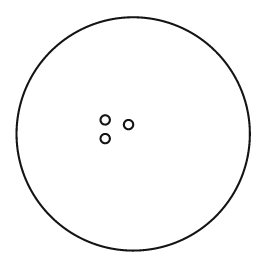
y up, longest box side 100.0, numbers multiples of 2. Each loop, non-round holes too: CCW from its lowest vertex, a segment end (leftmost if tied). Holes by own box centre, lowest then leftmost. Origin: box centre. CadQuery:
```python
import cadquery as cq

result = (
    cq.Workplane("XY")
    .moveTo(0.0, 0.0)
    .circle(50.0)
    .moveTo(-12.0, -2.0)
    .circle(2.0)
    .moveTo(-2.0, 4.0)
    .circle(2.0)
    .moveTo(-12.0, 6.0)
    .circle(2.0)
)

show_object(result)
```